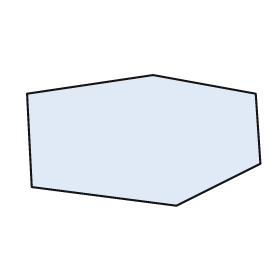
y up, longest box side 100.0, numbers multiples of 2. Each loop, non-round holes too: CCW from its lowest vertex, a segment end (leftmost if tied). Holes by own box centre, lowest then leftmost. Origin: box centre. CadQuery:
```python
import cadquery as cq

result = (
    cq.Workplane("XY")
    .moveTo(14.0, -28.0)
    .lineTo(50.0, -10.0)
    .lineTo(48.0, 20.0)
    .lineTo(4.0, 28.0)
    .lineTo(-50.0, 20.0)
    .lineTo(-48.0, -20.0)
    .close()
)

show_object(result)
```